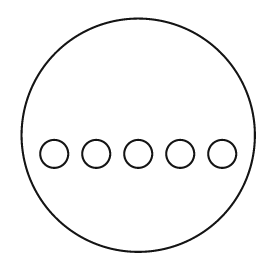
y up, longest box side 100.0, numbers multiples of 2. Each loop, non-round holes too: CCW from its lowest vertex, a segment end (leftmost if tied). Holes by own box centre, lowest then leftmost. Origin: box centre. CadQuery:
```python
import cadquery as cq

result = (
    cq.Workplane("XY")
    .moveTo(0.0, 0.0)
    .circle(50.0)
    .moveTo(-36.0, -8.0)
    .circle(6.0)
    .moveTo(-18.0, -8.0)
    .circle(6.0)
    .moveTo(0.0, -8.0)
    .circle(6.0)
    .moveTo(18.0, -8.0)
    .circle(6.0)
    .moveTo(36.0, -8.0)
    .circle(6.0)
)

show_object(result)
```